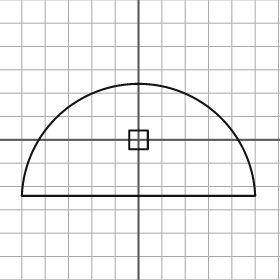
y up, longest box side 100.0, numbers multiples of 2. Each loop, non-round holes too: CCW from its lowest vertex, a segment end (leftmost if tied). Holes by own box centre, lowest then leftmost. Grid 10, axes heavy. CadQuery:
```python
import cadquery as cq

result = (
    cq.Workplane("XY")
    .moveTo(-50.0, -24.0)
    .lineTo(50.0, -24.0)
    .threePointArc((0.0, 24.0), (-50.0, -24.0))
    .close()
    .moveTo(-4.0, -4.0)
    .lineTo(4.0, -4.0)
    .lineTo(4.0, 4.0)
    .lineTo(-4.0, 4.0)
    .close()
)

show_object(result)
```